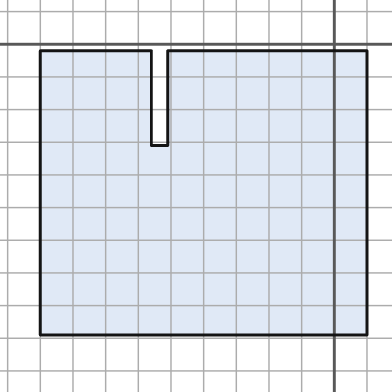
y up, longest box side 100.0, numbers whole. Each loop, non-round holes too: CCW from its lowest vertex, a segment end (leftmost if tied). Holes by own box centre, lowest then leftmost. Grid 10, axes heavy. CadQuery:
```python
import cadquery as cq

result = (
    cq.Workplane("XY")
    .moveTo(-90.0, -89.0)
    .lineTo(10.0, -89.0)
    .lineTo(10.0, -2.0)
    .lineTo(-51.0, -2.0)
    .lineTo(-51.0, -31.0)
    .lineTo(-56.0, -31.0)
    .lineTo(-56.0, -2.0)
    .lineTo(-90.0, -2.0)
    .close()
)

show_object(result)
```